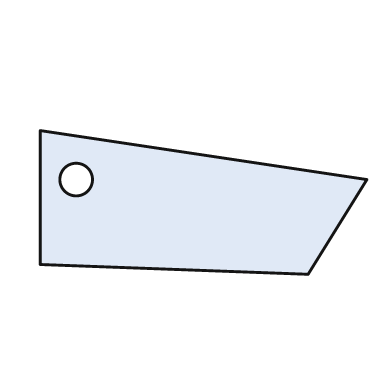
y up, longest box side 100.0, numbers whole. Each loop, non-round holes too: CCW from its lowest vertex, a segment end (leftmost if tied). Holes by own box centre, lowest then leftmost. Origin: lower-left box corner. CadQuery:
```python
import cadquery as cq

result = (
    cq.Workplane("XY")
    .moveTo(82.0, 0.0)
    .lineTo(100.0, 29.0)
    .lineTo(0.0, 44.0)
    .lineTo(0.0, 3.0)
    .close()
    .moveTo(11.0, 29.0)
    .circle(5.0)
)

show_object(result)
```